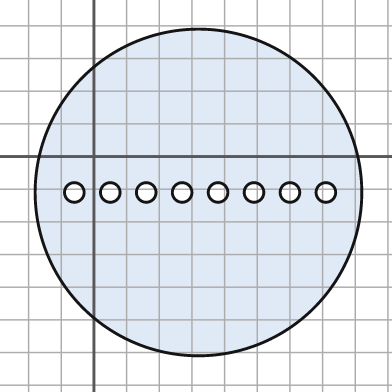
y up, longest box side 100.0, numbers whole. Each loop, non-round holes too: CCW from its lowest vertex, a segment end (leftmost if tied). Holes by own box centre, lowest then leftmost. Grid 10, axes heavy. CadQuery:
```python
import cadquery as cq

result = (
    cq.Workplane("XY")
    .moveTo(32.0, -11.0)
    .circle(50.0)
    .moveTo(-6.0, -11.0)
    .circle(3.0)
    .moveTo(5.0, -11.0)
    .circle(3.0)
    .moveTo(16.0, -11.0)
    .circle(3.0)
    .moveTo(27.0, -11.0)
    .circle(3.0)
    .moveTo(38.0, -11.0)
    .circle(3.0)
    .moveTo(49.0, -11.0)
    .circle(3.0)
    .moveTo(60.0, -11.0)
    .circle(3.0)
    .moveTo(71.0, -11.0)
    .circle(3.0)
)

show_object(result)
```